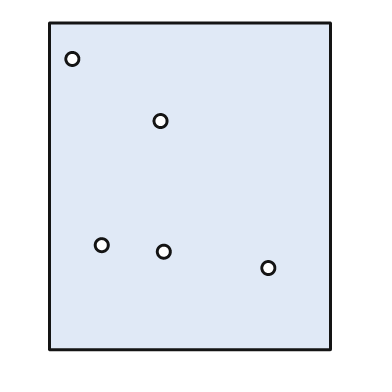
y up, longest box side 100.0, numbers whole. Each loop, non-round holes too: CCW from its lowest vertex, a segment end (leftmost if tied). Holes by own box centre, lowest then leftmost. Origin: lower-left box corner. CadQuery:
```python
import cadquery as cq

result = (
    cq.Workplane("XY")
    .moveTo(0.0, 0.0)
    .lineTo(86.0, 0.0)
    .lineTo(86.0, 100.0)
    .lineTo(0.0, 100.0)
    .close()
    .moveTo(67.0, 25.0)
    .circle(2.0)
    .moveTo(35.0, 30.0)
    .circle(2.0)
    .moveTo(16.0, 32.0)
    .circle(2.0)
    .moveTo(34.0, 70.0)
    .circle(2.0)
    .moveTo(7.0, 89.0)
    .circle(2.0)
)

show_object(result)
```